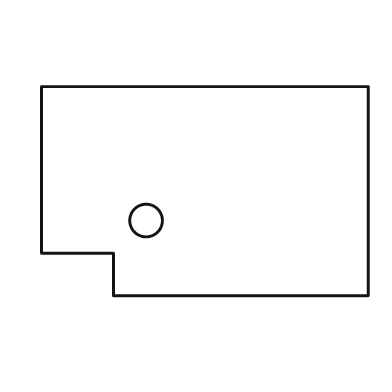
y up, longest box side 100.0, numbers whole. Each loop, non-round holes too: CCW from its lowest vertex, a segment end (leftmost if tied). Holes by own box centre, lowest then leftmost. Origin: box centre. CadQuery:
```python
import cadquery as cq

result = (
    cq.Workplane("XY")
    .moveTo(-28.0, -32.0)
    .lineTo(50.0, -32.0)
    .lineTo(50.0, 32.0)
    .lineTo(-50.0, 32.0)
    .lineTo(-50.0, -19.0)
    .lineTo(-28.0, -19.0)
    .close()
    .moveTo(-18.0, -9.0)
    .circle(5.0)
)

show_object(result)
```